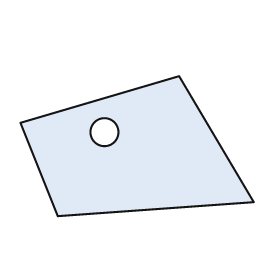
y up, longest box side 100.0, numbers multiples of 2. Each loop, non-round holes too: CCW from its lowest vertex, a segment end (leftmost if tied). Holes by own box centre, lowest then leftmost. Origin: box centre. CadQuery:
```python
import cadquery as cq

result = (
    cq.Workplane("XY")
    .moveTo(-34.0, -30.0)
    .lineTo(50.0, -24.0)
    .lineTo(18.0, 30.0)
    .lineTo(-50.0, 10.0)
    .close()
    .moveTo(-14.0, 6.0)
    .circle(6.0)
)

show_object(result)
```